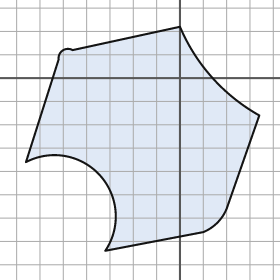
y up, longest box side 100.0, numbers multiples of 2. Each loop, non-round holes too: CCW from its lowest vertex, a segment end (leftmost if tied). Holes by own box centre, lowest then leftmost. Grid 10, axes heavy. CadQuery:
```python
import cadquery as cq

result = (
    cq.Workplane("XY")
    .moveTo(-32.0, -74.0)
    .lineTo(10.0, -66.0)
    .threePointArc((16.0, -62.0), (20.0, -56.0))
    .lineTo(34.0, -16.0)
    .threePointArc((14.0, 0.0), (0.0, 22.0))
    .lineTo(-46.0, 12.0)
    .threePointArc((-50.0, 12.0), (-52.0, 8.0))
    .lineTo(-66.0, -36.0)
    .threePointArc((-34.0, -42.0), (-32.0, -74.0))
    .close()
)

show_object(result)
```